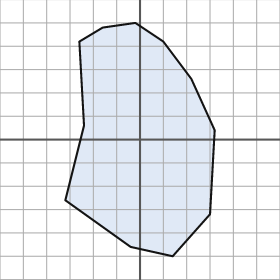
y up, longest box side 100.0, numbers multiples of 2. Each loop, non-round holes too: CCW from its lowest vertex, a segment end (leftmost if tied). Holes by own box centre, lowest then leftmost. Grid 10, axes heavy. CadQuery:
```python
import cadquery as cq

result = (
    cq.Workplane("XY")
    .moveTo(14.0, -50.0)
    .lineTo(30.0, -32.0)
    .lineTo(32.0, 4.0)
    .lineTo(22.0, 26.0)
    .lineTo(10.0, 42.0)
    .lineTo(-2.0, 50.0)
    .lineTo(-16.0, 48.0)
    .lineTo(-26.0, 42.0)
    .lineTo(-24.0, 6.0)
    .lineTo(-32.0, -26.0)
    .lineTo(-4.0, -46.0)
    .close()
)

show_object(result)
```